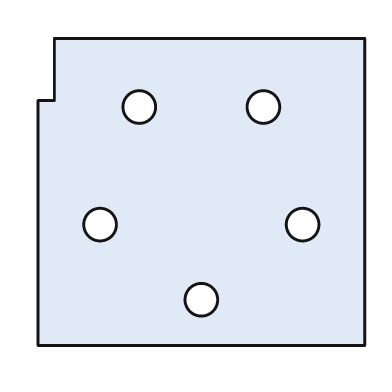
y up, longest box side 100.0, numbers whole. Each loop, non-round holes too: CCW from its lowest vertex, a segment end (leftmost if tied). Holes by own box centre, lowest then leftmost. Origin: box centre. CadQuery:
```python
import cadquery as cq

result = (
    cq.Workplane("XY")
    .moveTo(-50.0, -47.0)
    .lineTo(50.0, -47.0)
    .lineTo(50.0, 47.0)
    .lineTo(-45.0, 47.0)
    .lineTo(-45.0, 28.0)
    .lineTo(-50.0, 28.0)
    .close()
    .moveTo(0.0, -33.0)
    .circle(5.0)
    .moveTo(-31.0, -10.0)
    .circle(5.0)
    .moveTo(31.0, -10.0)
    .circle(5.0)
    .moveTo(-19.0, 26.0)
    .circle(5.0)
    .moveTo(19.0, 26.0)
    .circle(5.0)
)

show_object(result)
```